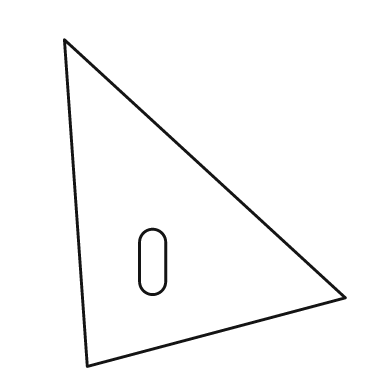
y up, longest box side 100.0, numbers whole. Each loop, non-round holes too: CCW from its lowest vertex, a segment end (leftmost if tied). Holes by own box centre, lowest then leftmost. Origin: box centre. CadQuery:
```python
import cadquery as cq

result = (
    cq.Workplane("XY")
    .moveTo(-36.0, -50.0)
    .lineTo(43.0, -29.0)
    .lineTo(-43.0, 50.0)
    .close()
    .moveTo(-20.0, -24.0)
    .threePointArc((-16.0, -28.0), (-12.0, -24.0))
    .lineTo(-12.0, -12.0)
    .threePointArc((-16.0, -8.0), (-20.0, -12.0))
    .close()
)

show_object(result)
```